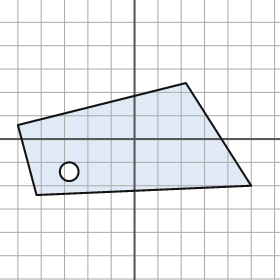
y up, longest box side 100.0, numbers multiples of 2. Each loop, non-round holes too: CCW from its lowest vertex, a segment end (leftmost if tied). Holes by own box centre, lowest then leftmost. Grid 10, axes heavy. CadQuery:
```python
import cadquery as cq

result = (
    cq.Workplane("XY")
    .moveTo(-42.0, -24.0)
    .lineTo(50.0, -20.0)
    .lineTo(22.0, 24.0)
    .lineTo(-50.0, 6.0)
    .close()
    .moveTo(-28.0, -14.0)
    .circle(4.0)
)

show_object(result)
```